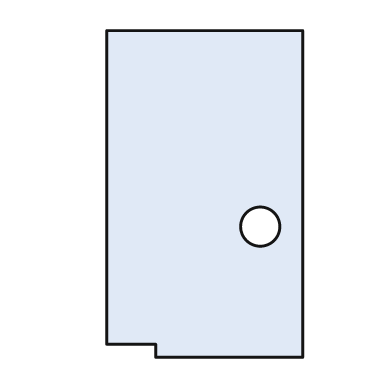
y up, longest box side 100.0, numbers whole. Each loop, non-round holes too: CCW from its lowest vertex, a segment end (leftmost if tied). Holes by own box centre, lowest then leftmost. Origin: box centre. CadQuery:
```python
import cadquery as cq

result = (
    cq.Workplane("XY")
    .moveTo(-15.0, -50.0)
    .lineTo(30.0, -50.0)
    .lineTo(30.0, 50.0)
    .lineTo(-30.0, 50.0)
    .lineTo(-30.0, -46.0)
    .lineTo(-15.0, -46.0)
    .close()
    .moveTo(17.0, -10.0)
    .circle(6.0)
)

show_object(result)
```